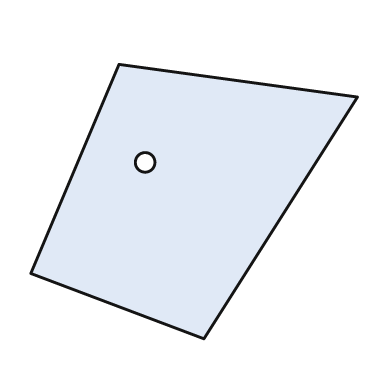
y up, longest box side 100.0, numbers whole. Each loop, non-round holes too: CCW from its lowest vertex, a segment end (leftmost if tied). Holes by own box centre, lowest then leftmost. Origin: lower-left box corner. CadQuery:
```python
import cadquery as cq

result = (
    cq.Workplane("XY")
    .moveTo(53.0, 0.0)
    .lineTo(100.0, 74.0)
    .lineTo(27.0, 84.0)
    .lineTo(0.0, 20.0)
    .close()
    .moveTo(35.0, 54.0)
    .circle(3.0)
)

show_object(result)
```